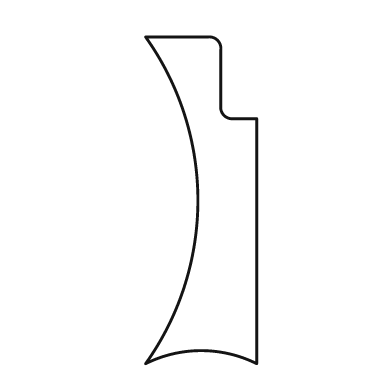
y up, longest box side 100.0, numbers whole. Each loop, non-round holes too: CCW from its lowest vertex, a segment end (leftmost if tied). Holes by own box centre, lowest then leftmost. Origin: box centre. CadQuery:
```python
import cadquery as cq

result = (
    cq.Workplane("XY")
    .moveTo(-17.0, -50.0)
    .threePointArc((0.0, -46.0), (17.0, -50.0))
    .lineTo(17.0, 25.0)
    .lineTo(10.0, 25.0)
    .threePointArc((7.0, 26.0), (6.0, 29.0))
    .lineTo(6.0, 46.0)
    .threePointArc((5.0, 49.0), (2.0, 50.0))
    .lineTo(-17.0, 50.0)
    .threePointArc((-1.0, 0.0), (-17.0, -50.0))
    .close()
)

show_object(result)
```